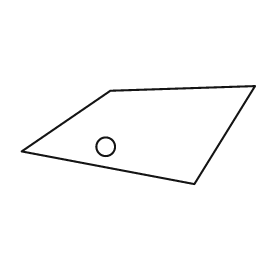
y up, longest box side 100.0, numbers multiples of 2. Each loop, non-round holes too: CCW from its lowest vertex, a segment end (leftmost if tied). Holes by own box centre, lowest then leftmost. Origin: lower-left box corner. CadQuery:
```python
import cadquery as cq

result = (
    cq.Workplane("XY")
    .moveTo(74.0, 0.0)
    .lineTo(100.0, 42.0)
    .lineTo(38.0, 40.0)
    .lineTo(0.0, 14.0)
    .close()
    .moveTo(36.0, 16.0)
    .circle(4.0)
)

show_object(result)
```